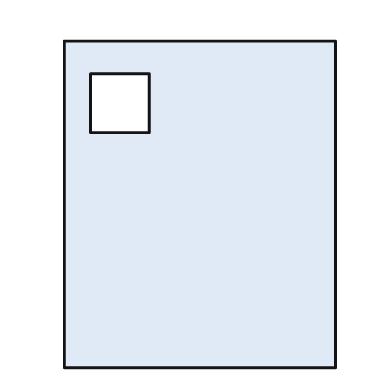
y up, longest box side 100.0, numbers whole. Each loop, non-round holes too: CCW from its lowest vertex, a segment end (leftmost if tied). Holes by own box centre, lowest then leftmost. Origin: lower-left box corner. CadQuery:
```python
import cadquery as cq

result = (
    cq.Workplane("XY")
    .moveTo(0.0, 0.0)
    .lineTo(83.0, 0.0)
    .lineTo(83.0, 100.0)
    .lineTo(0.0, 100.0)
    .close()
    .moveTo(8.0, 72.0)
    .lineTo(26.0, 72.0)
    .lineTo(26.0, 90.0)
    .lineTo(8.0, 90.0)
    .close()
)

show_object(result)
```